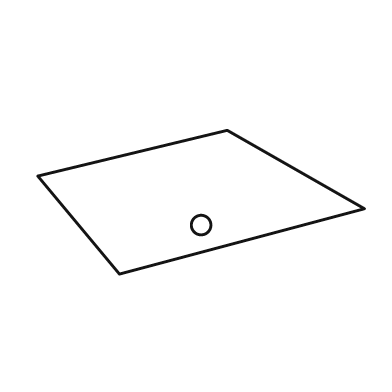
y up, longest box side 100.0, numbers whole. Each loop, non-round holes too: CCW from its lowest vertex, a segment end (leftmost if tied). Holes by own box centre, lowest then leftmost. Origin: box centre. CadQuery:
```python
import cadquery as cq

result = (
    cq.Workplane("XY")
    .moveTo(-25.0, -22.0)
    .lineTo(50.0, -2.0)
    .lineTo(8.0, 22.0)
    .lineTo(-50.0, 8.0)
    .close()
    .moveTo(0.0, -7.0)
    .circle(3.0)
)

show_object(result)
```